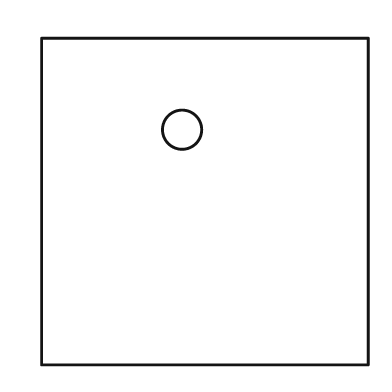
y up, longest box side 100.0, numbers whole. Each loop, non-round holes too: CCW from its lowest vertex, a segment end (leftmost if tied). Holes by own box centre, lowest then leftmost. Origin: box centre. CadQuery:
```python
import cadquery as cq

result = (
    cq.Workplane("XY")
    .moveTo(-50.0, -50.0)
    .lineTo(50.0, -50.0)
    .lineTo(50.0, 50.0)
    .lineTo(-50.0, 50.0)
    .close()
    .moveTo(-7.0, 22.0)
    .circle(6.0)
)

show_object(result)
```